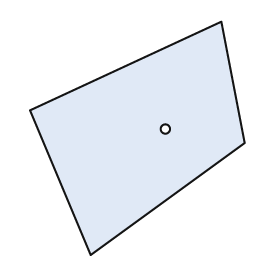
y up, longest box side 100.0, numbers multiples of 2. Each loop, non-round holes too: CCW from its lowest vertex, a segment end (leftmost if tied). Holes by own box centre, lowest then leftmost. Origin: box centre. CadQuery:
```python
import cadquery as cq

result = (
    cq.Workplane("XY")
    .moveTo(-20.0, -50.0)
    .lineTo(46.0, -2.0)
    .lineTo(36.0, 50.0)
    .lineTo(-46.0, 12.0)
    .close()
    .moveTo(12.0, 4.0)
    .circle(2.0)
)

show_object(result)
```